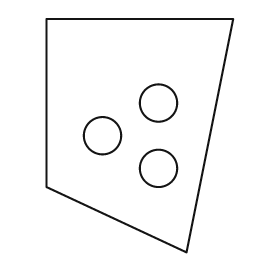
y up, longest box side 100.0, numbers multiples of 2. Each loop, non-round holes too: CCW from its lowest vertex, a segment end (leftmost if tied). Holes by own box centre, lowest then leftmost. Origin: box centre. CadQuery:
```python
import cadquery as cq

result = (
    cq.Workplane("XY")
    .moveTo(20.0, -50.0)
    .lineTo(40.0, 50.0)
    .lineTo(-40.0, 50.0)
    .lineTo(-40.0, -22.0)
    .close()
    .moveTo(8.0, -14.0)
    .circle(8.0)
    .moveTo(-16.0, 0.0)
    .circle(8.0)
    .moveTo(8.0, 14.0)
    .circle(8.0)
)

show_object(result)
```